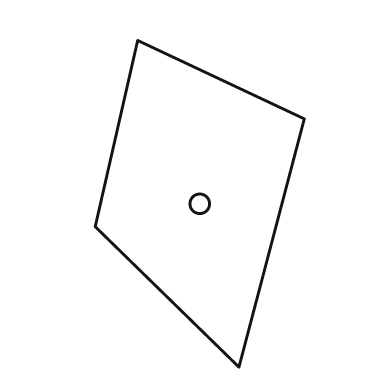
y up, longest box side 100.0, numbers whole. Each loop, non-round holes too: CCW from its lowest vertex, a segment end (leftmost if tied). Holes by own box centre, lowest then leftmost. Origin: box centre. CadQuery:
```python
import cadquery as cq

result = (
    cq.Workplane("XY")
    .moveTo(12.0, -50.0)
    .lineTo(32.0, 26.0)
    .lineTo(-19.0, 50.0)
    .lineTo(-32.0, -7.0)
    .close()
    .moveTo(0.0, 0.0)
    .circle(3.0)
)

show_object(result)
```